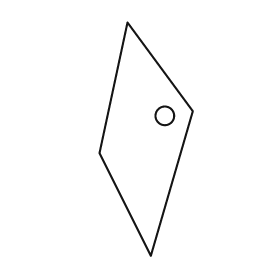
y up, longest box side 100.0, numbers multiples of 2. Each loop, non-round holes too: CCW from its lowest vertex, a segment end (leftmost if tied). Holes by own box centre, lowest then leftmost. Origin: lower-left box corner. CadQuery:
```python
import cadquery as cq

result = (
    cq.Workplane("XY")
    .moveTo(22.0, 0.0)
    .lineTo(40.0, 62.0)
    .lineTo(12.0, 100.0)
    .lineTo(0.0, 44.0)
    .close()
    .moveTo(28.0, 60.0)
    .circle(4.0)
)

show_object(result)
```